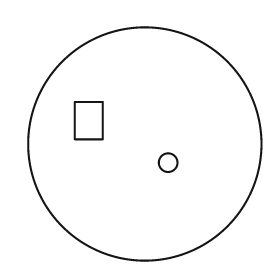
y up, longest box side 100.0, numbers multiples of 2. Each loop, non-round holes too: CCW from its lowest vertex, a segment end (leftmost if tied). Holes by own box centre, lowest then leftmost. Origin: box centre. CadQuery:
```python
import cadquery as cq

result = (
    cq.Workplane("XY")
    .moveTo(0.0, 0.0)
    .circle(50.0)
    .moveTo(10.0, -8.0)
    .circle(4.0)
    .moveTo(-30.0, 2.0)
    .lineTo(-18.0, 2.0)
    .lineTo(-18.0, 18.0)
    .lineTo(-30.0, 18.0)
    .close()
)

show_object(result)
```